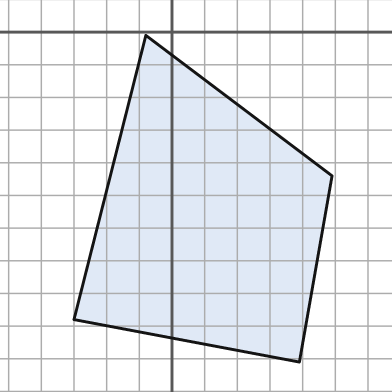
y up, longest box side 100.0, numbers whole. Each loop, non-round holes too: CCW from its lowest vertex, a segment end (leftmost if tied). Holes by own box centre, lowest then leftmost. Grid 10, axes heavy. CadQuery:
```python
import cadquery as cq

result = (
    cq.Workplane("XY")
    .moveTo(39.0, -101.0)
    .lineTo(49.0, -44.0)
    .lineTo(-8.0, -1.0)
    .lineTo(-30.0, -88.0)
    .close()
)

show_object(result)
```